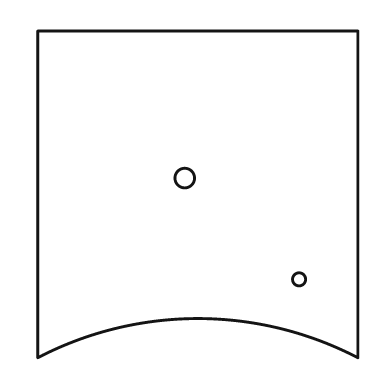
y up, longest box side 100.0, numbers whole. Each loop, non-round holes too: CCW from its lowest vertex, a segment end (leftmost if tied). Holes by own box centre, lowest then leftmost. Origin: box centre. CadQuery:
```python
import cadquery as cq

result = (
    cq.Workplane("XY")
    .moveTo(-49.0, -50.0)
    .threePointArc((0.0, -38.0), (49.0, -50.0))
    .lineTo(49.0, 50.0)
    .lineTo(-49.0, 50.0)
    .close()
    .moveTo(31.0, -26.0)
    .circle(2.0)
    .moveTo(-4.0, 5.0)
    .circle(3.0)
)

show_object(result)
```